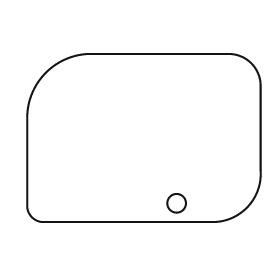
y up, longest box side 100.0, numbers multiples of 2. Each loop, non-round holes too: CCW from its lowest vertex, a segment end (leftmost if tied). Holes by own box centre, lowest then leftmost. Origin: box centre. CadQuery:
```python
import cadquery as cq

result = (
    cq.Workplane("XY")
    .moveTo(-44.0, -36.0)
    .lineTo(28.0, -36.0)
    .threePointArc((44.0, -30.0), (50.0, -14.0))
    .lineTo(50.0, 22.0)
    .threePointArc((46.0, 32.0), (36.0, 36.0))
    .lineTo(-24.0, 36.0)
    .threePointArc((-42.0, 28.0), (-50.0, 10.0))
    .lineTo(-50.0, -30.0)
    .threePointArc((-48.0, -34.0), (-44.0, -36.0))
    .close()
    .moveTo(14.0, -28.0)
    .circle(4.0)
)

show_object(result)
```